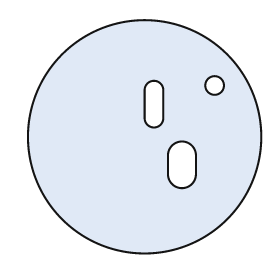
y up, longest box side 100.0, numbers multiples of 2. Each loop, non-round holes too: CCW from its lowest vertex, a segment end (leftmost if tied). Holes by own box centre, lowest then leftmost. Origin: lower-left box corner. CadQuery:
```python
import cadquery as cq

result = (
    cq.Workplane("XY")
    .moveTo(50.0, 50.0)
    .circle(50.0)
    .moveTo(60.0, 34.0)
    .threePointArc((66.0, 28.0), (72.0, 34.0))
    .lineTo(72.0, 42.0)
    .threePointArc((66.0, 48.0), (60.0, 42.0))
    .close()
    .moveTo(50.0, 58.0)
    .threePointArc((54.0, 54.0), (58.0, 58.0))
    .lineTo(58.0, 70.0)
    .threePointArc((54.0, 74.0), (50.0, 70.0))
    .close()
    .moveTo(80.0, 72.0)
    .circle(4.0)
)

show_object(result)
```